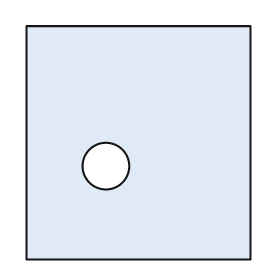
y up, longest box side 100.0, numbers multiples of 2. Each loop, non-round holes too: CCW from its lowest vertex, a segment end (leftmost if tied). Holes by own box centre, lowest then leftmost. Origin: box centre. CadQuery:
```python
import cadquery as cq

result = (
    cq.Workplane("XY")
    .moveTo(-48.0, -50.0)
    .lineTo(48.0, -50.0)
    .lineTo(48.0, 50.0)
    .lineTo(-48.0, 50.0)
    .close()
    .moveTo(-14.0, -10.0)
    .circle(10.0)
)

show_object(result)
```